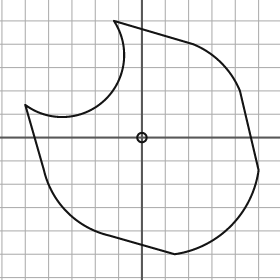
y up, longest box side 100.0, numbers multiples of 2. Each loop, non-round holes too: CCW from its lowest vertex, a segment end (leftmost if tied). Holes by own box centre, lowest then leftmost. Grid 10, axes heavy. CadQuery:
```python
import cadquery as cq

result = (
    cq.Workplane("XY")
    .moveTo(14.0, -50.0)
    .threePointArc((38.0, -38.0), (50.0, -14.0))
    .lineTo(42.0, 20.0)
    .threePointArc((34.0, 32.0), (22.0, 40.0))
    .lineTo(-12.0, 50.0)
    .threePointArc((-16.0, 16.0), (-50.0, 14.0))
    .lineTo(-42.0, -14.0)
    .threePointArc((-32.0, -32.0), (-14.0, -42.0))
    .close()
    .moveTo(0.0, 0.0)
    .circle(2.0)
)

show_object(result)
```